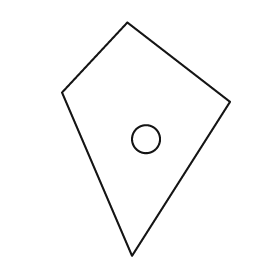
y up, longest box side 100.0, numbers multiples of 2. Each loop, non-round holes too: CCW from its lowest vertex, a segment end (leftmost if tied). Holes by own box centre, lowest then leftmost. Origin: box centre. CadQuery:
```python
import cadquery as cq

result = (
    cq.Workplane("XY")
    .moveTo(-6.0, -50.0)
    .lineTo(36.0, 16.0)
    .lineTo(-8.0, 50.0)
    .lineTo(-36.0, 20.0)
    .close()
    .moveTo(0.0, 0.0)
    .circle(6.0)
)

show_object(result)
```